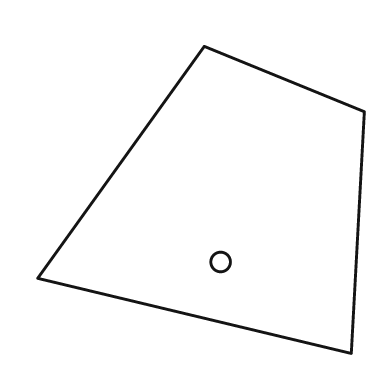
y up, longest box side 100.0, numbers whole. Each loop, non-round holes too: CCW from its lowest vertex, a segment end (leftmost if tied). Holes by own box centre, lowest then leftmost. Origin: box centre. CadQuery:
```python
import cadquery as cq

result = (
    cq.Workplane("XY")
    .moveTo(46.0, -47.0)
    .lineTo(50.0, 27.0)
    .lineTo(1.0, 47.0)
    .lineTo(-50.0, -24.0)
    .close()
    .moveTo(6.0, -19.0)
    .circle(3.0)
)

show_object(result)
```